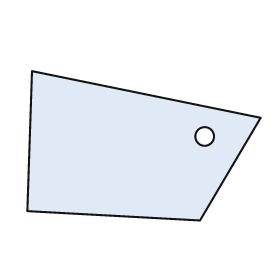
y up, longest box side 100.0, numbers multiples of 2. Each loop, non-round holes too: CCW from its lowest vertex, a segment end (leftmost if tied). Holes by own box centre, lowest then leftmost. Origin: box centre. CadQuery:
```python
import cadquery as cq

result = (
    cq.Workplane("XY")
    .moveTo(24.0, -32.0)
    .lineTo(50.0, 12.0)
    .lineTo(-48.0, 32.0)
    .lineTo(-50.0, -28.0)
    .close()
    .moveTo(26.0, 4.0)
    .circle(4.0)
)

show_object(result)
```